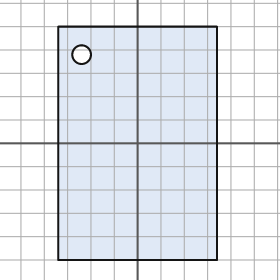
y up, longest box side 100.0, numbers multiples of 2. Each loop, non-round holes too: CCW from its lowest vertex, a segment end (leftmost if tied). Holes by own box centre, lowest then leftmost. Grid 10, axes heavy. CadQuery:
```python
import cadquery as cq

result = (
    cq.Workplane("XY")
    .moveTo(-34.0, -50.0)
    .lineTo(34.0, -50.0)
    .lineTo(34.0, 50.0)
    .lineTo(-34.0, 50.0)
    .close()
    .moveTo(-24.0, 38.0)
    .circle(4.0)
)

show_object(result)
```